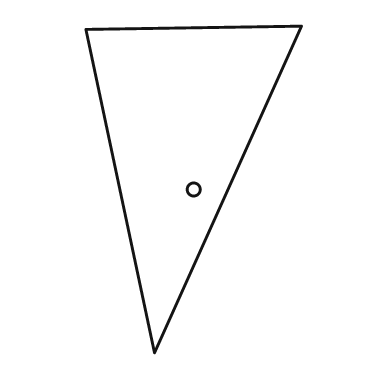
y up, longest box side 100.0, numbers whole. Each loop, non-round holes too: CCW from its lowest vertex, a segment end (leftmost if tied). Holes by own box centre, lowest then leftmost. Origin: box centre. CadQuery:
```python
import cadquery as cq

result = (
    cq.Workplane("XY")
    .moveTo(-12.0, -50.0)
    .lineTo(33.0, 50.0)
    .lineTo(-33.0, 49.0)
    .close()
    .moveTo(0.0, 0.0)
    .circle(2.0)
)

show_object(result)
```